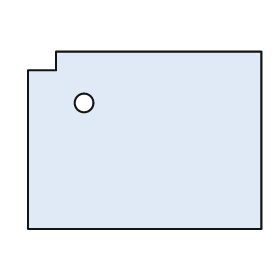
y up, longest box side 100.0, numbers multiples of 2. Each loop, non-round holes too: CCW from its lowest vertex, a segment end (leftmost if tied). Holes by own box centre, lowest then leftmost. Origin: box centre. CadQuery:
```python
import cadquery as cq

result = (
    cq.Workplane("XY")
    .moveTo(-50.0, -38.0)
    .lineTo(50.0, -38.0)
    .lineTo(50.0, 38.0)
    .lineTo(-38.0, 38.0)
    .lineTo(-38.0, 30.0)
    .lineTo(-50.0, 30.0)
    .close()
    .moveTo(-26.0, 16.0)
    .circle(4.0)
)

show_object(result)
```